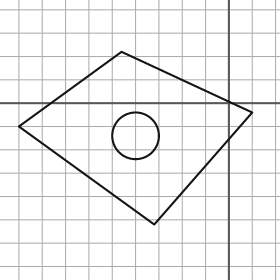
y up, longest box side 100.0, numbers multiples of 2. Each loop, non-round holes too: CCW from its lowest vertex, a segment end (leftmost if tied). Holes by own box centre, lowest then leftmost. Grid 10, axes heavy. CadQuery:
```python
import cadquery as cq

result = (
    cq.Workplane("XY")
    .moveTo(-32.0, -52.0)
    .lineTo(10.0, -4.0)
    .lineTo(-46.0, 22.0)
    .lineTo(-90.0, -10.0)
    .close()
    .moveTo(-40.0, -14.0)
    .circle(10.0)
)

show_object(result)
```